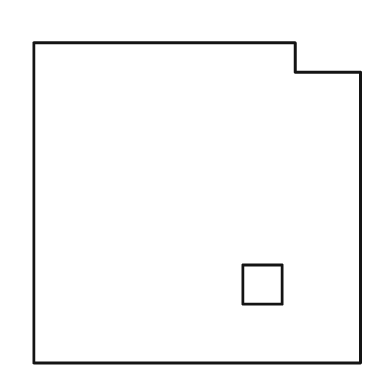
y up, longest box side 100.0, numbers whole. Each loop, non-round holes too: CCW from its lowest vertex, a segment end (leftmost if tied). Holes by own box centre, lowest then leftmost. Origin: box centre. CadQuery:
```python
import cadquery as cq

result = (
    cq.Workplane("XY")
    .moveTo(-50.0, -49.0)
    .lineTo(50.0, -49.0)
    .lineTo(50.0, 40.0)
    .lineTo(30.0, 40.0)
    .lineTo(30.0, 49.0)
    .lineTo(-50.0, 49.0)
    .close()
    .moveTo(14.0, -31.0)
    .lineTo(26.0, -31.0)
    .lineTo(26.0, -19.0)
    .lineTo(14.0, -19.0)
    .close()
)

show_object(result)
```